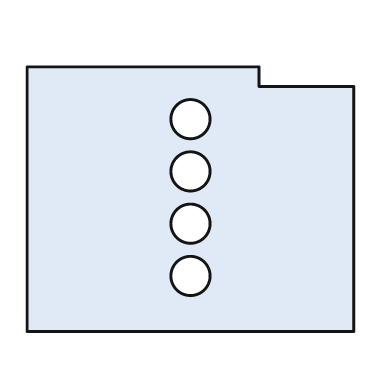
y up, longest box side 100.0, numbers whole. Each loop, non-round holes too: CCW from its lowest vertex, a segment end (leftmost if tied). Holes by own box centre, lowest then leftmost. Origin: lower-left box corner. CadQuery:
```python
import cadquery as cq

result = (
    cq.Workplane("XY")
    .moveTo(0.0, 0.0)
    .lineTo(100.0, 0.0)
    .lineTo(100.0, 75.0)
    .lineTo(71.0, 75.0)
    .lineTo(71.0, 81.0)
    .lineTo(0.0, 81.0)
    .close()
    .moveTo(50.0, 17.0)
    .circle(6.0)
    .moveTo(50.0, 33.0)
    .circle(6.0)
    .moveTo(50.0, 49.0)
    .circle(6.0)
    .moveTo(50.0, 65.0)
    .circle(6.0)
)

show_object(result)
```